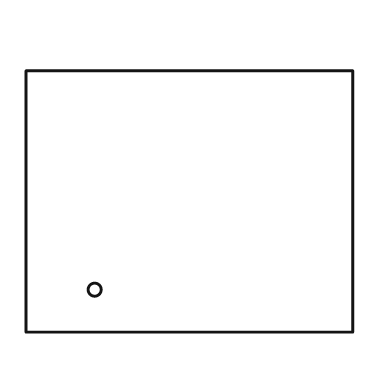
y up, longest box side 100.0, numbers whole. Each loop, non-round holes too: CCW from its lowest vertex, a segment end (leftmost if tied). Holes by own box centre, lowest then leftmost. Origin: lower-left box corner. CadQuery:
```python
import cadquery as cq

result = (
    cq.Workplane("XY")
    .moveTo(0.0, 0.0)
    .lineTo(100.0, 0.0)
    .lineTo(100.0, 80.0)
    .lineTo(0.0, 80.0)
    .close()
    .moveTo(21.0, 13.0)
    .circle(2.0)
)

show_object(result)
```